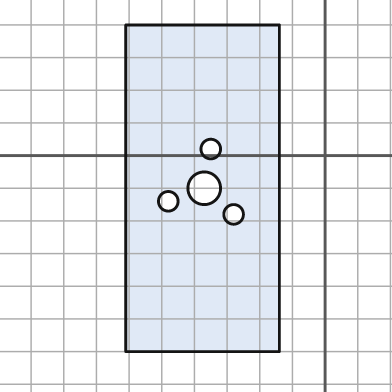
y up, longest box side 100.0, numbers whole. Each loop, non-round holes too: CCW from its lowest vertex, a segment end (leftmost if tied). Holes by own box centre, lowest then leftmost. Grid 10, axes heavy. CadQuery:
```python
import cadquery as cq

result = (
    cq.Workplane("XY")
    .moveTo(-61.0, -60.0)
    .lineTo(-14.0, -60.0)
    .lineTo(-14.0, 40.0)
    .lineTo(-61.0, 40.0)
    .close()
    .moveTo(-28.0, -18.0)
    .circle(3.0)
    .moveTo(-48.0, -14.0)
    .circle(3.0)
    .moveTo(-37.0, -10.0)
    .circle(5.0)
    .moveTo(-35.0, 2.0)
    .circle(3.0)
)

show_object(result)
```